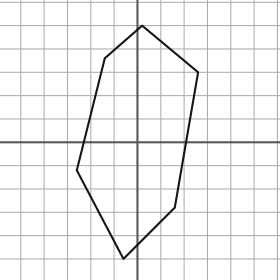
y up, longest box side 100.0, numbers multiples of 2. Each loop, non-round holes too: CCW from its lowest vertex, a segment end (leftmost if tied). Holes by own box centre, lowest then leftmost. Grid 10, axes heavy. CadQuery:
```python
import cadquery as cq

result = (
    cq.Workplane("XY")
    .moveTo(-6.0, -50.0)
    .lineTo(16.0, -28.0)
    .lineTo(26.0, 30.0)
    .lineTo(2.0, 50.0)
    .lineTo(-14.0, 36.0)
    .lineTo(-26.0, -12.0)
    .close()
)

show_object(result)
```